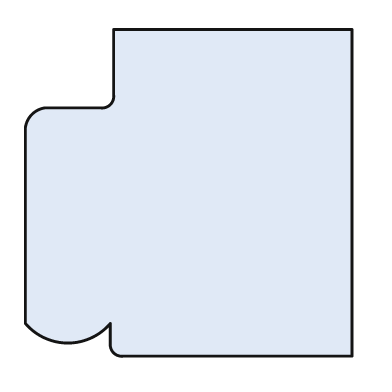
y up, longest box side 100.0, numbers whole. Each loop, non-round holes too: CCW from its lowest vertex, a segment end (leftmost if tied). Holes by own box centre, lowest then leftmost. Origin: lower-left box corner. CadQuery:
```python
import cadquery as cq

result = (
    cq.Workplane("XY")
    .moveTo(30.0, 0.0)
    .lineTo(100.0, 0.0)
    .lineTo(100.0, 100.0)
    .lineTo(27.0, 100.0)
    .lineTo(27.0, 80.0)
    .threePointArc((26.0, 77.0), (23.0, 76.0))
    .lineTo(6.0, 76.0)
    .threePointArc((2.0, 74.0), (0.0, 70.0))
    .lineTo(0.0, 10.0)
    .threePointArc((13.0, 4.0), (26.0, 10.0))
    .lineTo(26.0, 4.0)
    .threePointArc((27.0, 1.0), (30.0, 0.0))
    .close()
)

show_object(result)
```